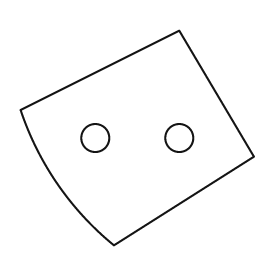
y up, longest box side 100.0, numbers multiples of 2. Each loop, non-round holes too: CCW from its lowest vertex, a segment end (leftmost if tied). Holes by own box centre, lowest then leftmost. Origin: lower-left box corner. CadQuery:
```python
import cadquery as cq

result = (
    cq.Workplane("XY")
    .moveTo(40.0, 0.0)
    .lineTo(100.0, 38.0)
    .lineTo(68.0, 92.0)
    .lineTo(0.0, 58.0)
    .threePointArc((16.0, 26.0), (40.0, 0.0))
    .close()
    .moveTo(32.0, 46.0)
    .circle(6.0)
    .moveTo(68.0, 46.0)
    .circle(6.0)
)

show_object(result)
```